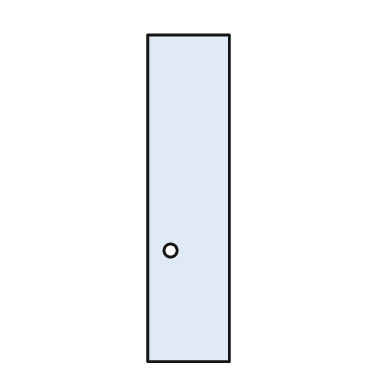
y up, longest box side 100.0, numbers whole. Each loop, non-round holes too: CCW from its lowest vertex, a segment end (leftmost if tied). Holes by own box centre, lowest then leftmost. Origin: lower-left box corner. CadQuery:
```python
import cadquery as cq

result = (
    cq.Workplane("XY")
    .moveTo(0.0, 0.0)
    .lineTo(25.0, 0.0)
    .lineTo(25.0, 100.0)
    .lineTo(0.0, 100.0)
    .close()
    .moveTo(7.0, 34.0)
    .circle(2.0)
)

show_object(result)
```